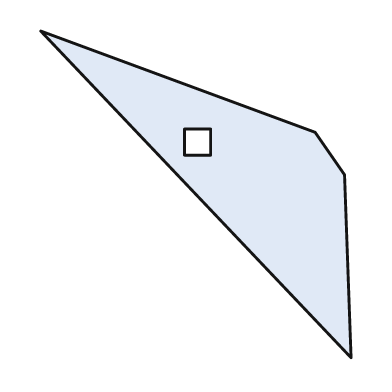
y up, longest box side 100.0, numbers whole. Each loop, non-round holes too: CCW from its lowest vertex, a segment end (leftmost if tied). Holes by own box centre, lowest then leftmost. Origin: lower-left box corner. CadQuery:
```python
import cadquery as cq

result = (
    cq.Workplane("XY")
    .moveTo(95.0, 0.0)
    .lineTo(93.0, 56.0)
    .lineTo(84.0, 69.0)
    .lineTo(0.0, 100.0)
    .close()
    .moveTo(44.0, 62.0)
    .lineTo(52.0, 62.0)
    .lineTo(52.0, 70.0)
    .lineTo(44.0, 70.0)
    .close()
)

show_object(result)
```